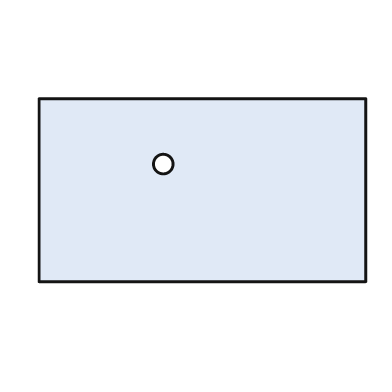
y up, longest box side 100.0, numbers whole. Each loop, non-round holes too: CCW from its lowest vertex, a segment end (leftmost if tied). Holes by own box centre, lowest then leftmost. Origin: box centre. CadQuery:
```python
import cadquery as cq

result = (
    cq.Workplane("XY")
    .moveTo(-50.0, -28.0)
    .lineTo(50.0, -28.0)
    .lineTo(50.0, 28.0)
    .lineTo(-50.0, 28.0)
    .close()
    .moveTo(-12.0, 8.0)
    .circle(3.0)
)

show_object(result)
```